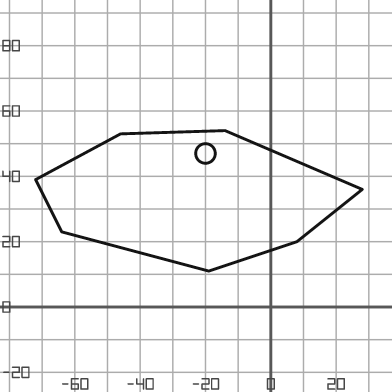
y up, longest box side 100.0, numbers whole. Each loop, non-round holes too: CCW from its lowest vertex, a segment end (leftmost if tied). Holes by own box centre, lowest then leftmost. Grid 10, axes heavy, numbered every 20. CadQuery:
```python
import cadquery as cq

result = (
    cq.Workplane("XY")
    .moveTo(-19.0, 11.0)
    .lineTo(8.0, 20.0)
    .lineTo(28.0, 36.0)
    .lineTo(-14.0, 54.0)
    .lineTo(-46.0, 53.0)
    .lineTo(-72.0, 39.0)
    .lineTo(-64.0, 23.0)
    .close()
    .moveTo(-20.0, 47.0)
    .circle(3.0)
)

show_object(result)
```